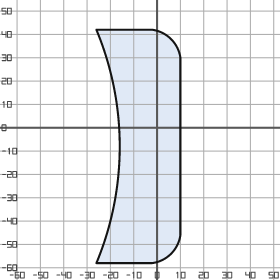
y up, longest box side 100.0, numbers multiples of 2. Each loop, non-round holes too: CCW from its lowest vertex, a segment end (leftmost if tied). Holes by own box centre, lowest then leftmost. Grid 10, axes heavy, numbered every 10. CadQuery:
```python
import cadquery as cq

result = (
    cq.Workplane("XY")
    .moveTo(-26.0, -58.0)
    .lineTo(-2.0, -58.0)
    .threePointArc((6.0, -54.0), (10.0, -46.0))
    .lineTo(10.0, 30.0)
    .threePointArc((6.0, 38.0), (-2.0, 42.0))
    .lineTo(-26.0, 42.0)
    .threePointArc((-16.0, -8.0), (-26.0, -58.0))
    .close()
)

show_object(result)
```